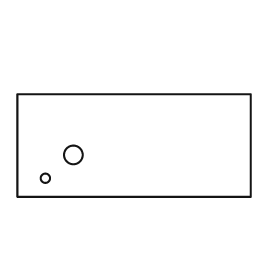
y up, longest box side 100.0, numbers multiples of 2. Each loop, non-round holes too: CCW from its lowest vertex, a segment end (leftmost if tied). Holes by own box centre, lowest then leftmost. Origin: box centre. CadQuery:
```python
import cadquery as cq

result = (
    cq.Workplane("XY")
    .moveTo(-50.0, -22.0)
    .lineTo(50.0, -22.0)
    .lineTo(50.0, 22.0)
    .lineTo(-50.0, 22.0)
    .close()
    .moveTo(-38.0, -14.0)
    .circle(2.0)
    .moveTo(-26.0, -4.0)
    .circle(4.0)
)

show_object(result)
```